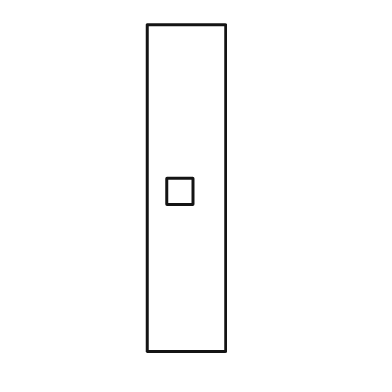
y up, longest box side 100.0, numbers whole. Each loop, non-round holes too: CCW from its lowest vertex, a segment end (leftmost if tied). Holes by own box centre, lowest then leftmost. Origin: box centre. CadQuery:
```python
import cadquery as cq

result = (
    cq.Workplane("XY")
    .moveTo(-12.0, -50.0)
    .lineTo(12.0, -50.0)
    .lineTo(12.0, 50.0)
    .lineTo(-12.0, 50.0)
    .close()
    .moveTo(-6.0, -5.0)
    .lineTo(2.0, -5.0)
    .lineTo(2.0, 3.0)
    .lineTo(-6.0, 3.0)
    .close()
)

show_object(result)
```